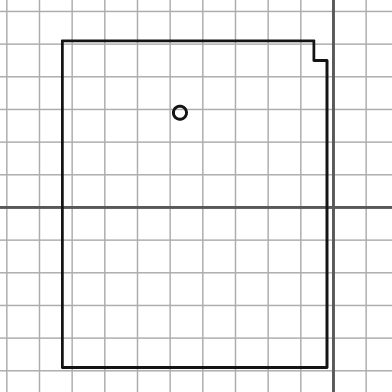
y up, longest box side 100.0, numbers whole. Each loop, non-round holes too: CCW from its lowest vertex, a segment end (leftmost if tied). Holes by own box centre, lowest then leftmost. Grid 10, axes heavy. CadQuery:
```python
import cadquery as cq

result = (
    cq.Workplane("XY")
    .moveTo(-83.0, -49.0)
    .lineTo(-2.0, -49.0)
    .lineTo(-2.0, 45.0)
    .lineTo(-6.0, 45.0)
    .lineTo(-6.0, 51.0)
    .lineTo(-83.0, 51.0)
    .close()
    .moveTo(-47.0, 29.0)
    .circle(2.0)
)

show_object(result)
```